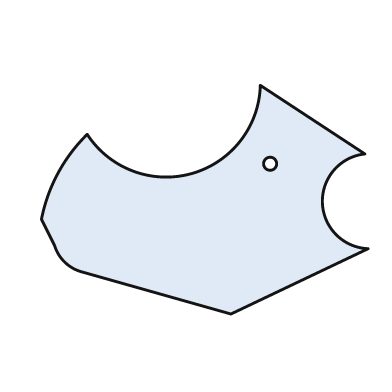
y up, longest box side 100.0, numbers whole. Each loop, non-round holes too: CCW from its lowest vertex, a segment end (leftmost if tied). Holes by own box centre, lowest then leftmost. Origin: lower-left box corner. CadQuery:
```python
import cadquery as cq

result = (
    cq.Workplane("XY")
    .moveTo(58.0, 0.0)
    .lineTo(100.0, 20.0)
    .threePointArc((86.0, 34.0), (99.0, 49.0))
    .lineTo(67.0, 70.0)
    .threePointArc((46.0, 43.0), (14.0, 55.0))
    .threePointArc((5.0, 43.0), (0.0, 29.0))
    .lineTo(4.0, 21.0)
    .threePointArc((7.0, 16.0), (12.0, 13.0))
    .close()
    .moveTo(70.0, 46.0)
    .circle(2.0)
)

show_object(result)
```